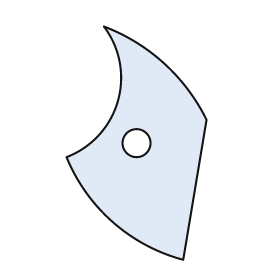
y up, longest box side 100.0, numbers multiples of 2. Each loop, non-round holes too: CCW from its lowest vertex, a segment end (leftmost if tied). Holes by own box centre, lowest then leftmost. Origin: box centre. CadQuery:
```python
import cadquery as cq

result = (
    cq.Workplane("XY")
    .moveTo(20.0, -50.0)
    .lineTo(30.0, 10.0)
    .threePointArc((12.0, 34.0), (-14.0, 50.0))
    .threePointArc((-8.0, 18.0), (-30.0, -6.0))
    .threePointArc((-10.0, -34.0), (20.0, -50.0))
    .close()
    .moveTo(0.0, 0.0)
    .circle(6.0)
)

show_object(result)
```